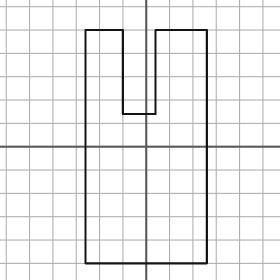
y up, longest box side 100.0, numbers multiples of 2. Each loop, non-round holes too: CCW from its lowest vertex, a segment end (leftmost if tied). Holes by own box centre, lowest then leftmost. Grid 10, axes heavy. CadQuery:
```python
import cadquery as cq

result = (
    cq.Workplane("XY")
    .moveTo(-26.0, -50.0)
    .lineTo(26.0, -50.0)
    .lineTo(26.0, 50.0)
    .lineTo(4.0, 50.0)
    .lineTo(4.0, 14.0)
    .lineTo(-10.0, 14.0)
    .lineTo(-10.0, 50.0)
    .lineTo(-26.0, 50.0)
    .close()
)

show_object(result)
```